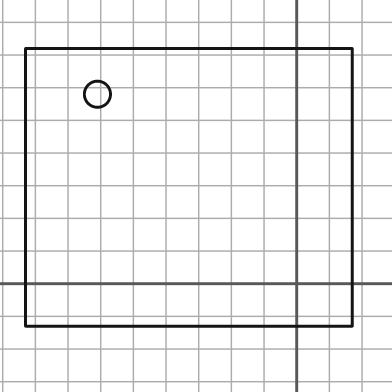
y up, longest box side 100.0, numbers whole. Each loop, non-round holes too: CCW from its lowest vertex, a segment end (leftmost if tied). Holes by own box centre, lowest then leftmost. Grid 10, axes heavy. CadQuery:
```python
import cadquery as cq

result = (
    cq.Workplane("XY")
    .moveTo(-83.0, -13.0)
    .lineTo(17.0, -13.0)
    .lineTo(17.0, 72.0)
    .lineTo(-83.0, 72.0)
    .close()
    .moveTo(-61.0, 58.0)
    .circle(4.0)
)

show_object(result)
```